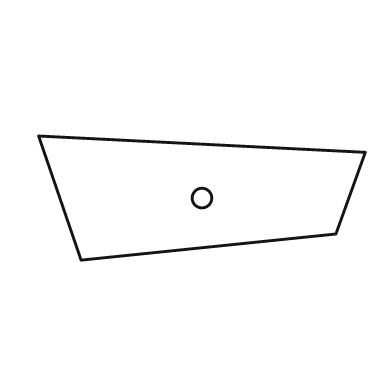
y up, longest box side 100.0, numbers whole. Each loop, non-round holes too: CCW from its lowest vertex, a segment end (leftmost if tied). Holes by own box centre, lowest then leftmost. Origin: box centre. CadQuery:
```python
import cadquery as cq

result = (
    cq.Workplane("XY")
    .moveTo(-37.0, -19.0)
    .lineTo(41.0, -11.0)
    .lineTo(50.0, 14.0)
    .lineTo(-50.0, 19.0)
    .close()
    .moveTo(0.0, 0.0)
    .circle(3.0)
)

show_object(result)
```